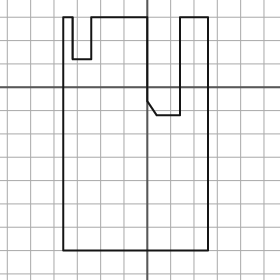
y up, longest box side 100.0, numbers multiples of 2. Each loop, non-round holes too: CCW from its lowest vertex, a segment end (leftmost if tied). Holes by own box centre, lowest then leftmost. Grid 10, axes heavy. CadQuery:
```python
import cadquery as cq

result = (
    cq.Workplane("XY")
    .moveTo(-36.0, -70.0)
    .lineTo(26.0, -70.0)
    .lineTo(26.0, 30.0)
    .lineTo(14.0, 30.0)
    .lineTo(14.0, -12.0)
    .lineTo(4.0, -12.0)
    .lineTo(0.0, -6.0)
    .lineTo(0.0, 30.0)
    .lineTo(-24.0, 30.0)
    .lineTo(-24.0, 12.0)
    .lineTo(-32.0, 12.0)
    .lineTo(-32.0, 30.0)
    .lineTo(-36.0, 30.0)
    .close()
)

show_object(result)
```